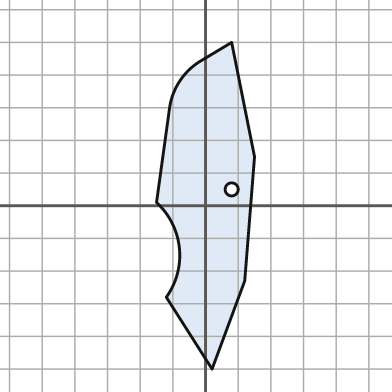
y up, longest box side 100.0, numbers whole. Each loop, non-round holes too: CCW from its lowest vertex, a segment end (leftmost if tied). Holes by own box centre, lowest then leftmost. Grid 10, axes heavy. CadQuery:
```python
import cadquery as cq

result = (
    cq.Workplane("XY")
    .moveTo(2.0, -50.0)
    .lineTo(12.0, -23.0)
    .lineTo(15.0, 15.0)
    .lineTo(8.0, 50.0)
    .lineTo(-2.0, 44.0)
    .threePointArc((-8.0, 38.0), (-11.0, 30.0))
    .lineTo(-15.0, 1.0)
    .threePointArc((-8.0, -13.0), (-12.0, -28.0))
    .close()
    .moveTo(8.0, 5.0)
    .circle(2.0)
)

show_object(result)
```